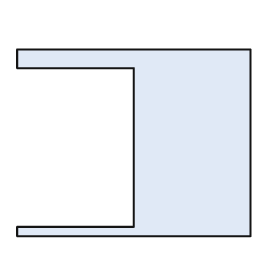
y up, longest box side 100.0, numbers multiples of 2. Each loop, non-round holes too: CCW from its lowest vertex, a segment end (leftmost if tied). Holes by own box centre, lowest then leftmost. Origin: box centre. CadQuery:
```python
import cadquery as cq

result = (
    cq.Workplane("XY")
    .moveTo(-50.0, -40.0)
    .lineTo(50.0, -40.0)
    .lineTo(50.0, 40.0)
    .lineTo(-50.0, 40.0)
    .lineTo(-50.0, 32.0)
    .lineTo(0.0, 32.0)
    .lineTo(0.0, -36.0)
    .lineTo(-50.0, -36.0)
    .close()
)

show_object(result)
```